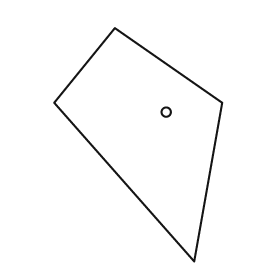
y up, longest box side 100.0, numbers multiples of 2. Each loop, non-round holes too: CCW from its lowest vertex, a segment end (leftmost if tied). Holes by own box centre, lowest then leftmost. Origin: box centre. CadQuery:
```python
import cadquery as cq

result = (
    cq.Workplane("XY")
    .moveTo(24.0, -50.0)
    .lineTo(36.0, 18.0)
    .lineTo(-10.0, 50.0)
    .lineTo(-36.0, 18.0)
    .close()
    .moveTo(12.0, 14.0)
    .circle(2.0)
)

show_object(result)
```